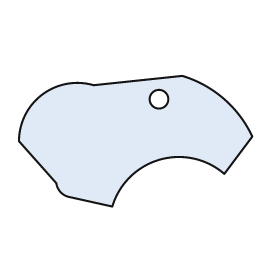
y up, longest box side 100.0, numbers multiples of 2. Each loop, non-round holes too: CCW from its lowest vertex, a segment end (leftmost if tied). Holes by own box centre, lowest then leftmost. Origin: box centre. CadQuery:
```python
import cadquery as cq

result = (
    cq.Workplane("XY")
    .moveTo(-10.0, -28.0)
    .threePointArc((10.0, -8.0), (38.0, -14.0))
    .lineTo(50.0, 2.0)
    .threePointArc((38.0, 18.0), (20.0, 28.0))
    .lineTo(-18.0, 24.0)
    .threePointArc((-40.0, 20.0), (-50.0, 0.0))
    .lineTo(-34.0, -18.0)
    .threePointArc((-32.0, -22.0), (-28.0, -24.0))
    .close()
    .moveTo(10.0, 18.0)
    .circle(4.0)
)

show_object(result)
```